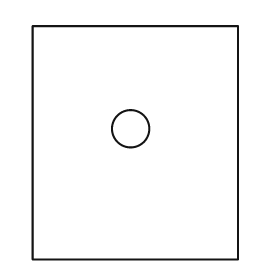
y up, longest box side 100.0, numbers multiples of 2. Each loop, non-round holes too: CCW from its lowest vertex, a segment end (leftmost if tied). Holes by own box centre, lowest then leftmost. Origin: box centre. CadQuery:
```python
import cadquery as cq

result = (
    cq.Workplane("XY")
    .moveTo(-44.0, -50.0)
    .lineTo(44.0, -50.0)
    .lineTo(44.0, 50.0)
    .lineTo(-44.0, 50.0)
    .close()
    .moveTo(-2.0, 6.0)
    .circle(8.0)
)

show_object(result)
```